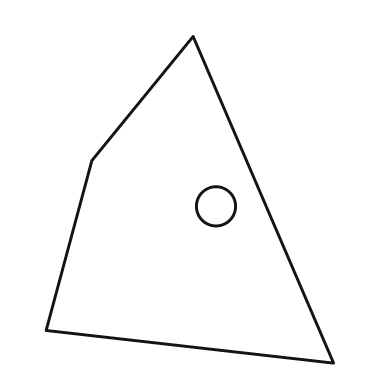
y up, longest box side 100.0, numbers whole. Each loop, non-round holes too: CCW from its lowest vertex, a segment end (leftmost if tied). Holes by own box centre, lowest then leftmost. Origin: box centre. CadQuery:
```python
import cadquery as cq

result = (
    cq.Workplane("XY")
    .moveTo(44.0, -50.0)
    .lineTo(1.0, 50.0)
    .lineTo(-30.0, 12.0)
    .lineTo(-44.0, -40.0)
    .close()
    .moveTo(8.0, -2.0)
    .circle(6.0)
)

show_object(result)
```